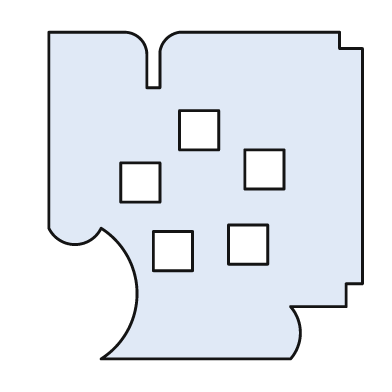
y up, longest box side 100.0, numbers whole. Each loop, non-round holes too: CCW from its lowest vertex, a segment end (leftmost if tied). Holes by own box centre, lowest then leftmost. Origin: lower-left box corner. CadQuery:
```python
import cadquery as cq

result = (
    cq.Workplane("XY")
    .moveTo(16.0, 0.0)
    .lineTo(74.0, 0.0)
    .threePointArc((77.0, 8.0), (74.0, 16.0))
    .lineTo(91.0, 16.0)
    .lineTo(91.0, 23.0)
    .lineTo(96.0, 23.0)
    .lineTo(96.0, 95.0)
    .lineTo(89.0, 95.0)
    .lineTo(89.0, 100.0)
    .lineTo(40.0, 100.0)
    .threePointArc((36.0, 98.0), (34.0, 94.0))
    .lineTo(34.0, 83.0)
    .lineTo(30.0, 83.0)
    .lineTo(30.0, 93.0)
    .threePointArc((28.0, 98.0), (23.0, 100.0))
    .lineTo(0.0, 100.0)
    .lineTo(0.0, 40.0)
    .threePointArc((8.0, 35.0), (16.0, 40.0))
    .threePointArc((27.0, 20.0), (16.0, 0.0))
    .close()
    .moveTo(32.0, 27.0)
    .lineTo(44.0, 27.0)
    .lineTo(44.0, 39.0)
    .lineTo(32.0, 39.0)
    .close()
    .moveTo(55.0, 29.0)
    .lineTo(67.0, 29.0)
    .lineTo(67.0, 41.0)
    .lineTo(55.0, 41.0)
    .close()
    .moveTo(22.0, 48.0)
    .lineTo(34.0, 48.0)
    .lineTo(34.0, 60.0)
    .lineTo(22.0, 60.0)
    .close()
    .moveTo(60.0, 52.0)
    .lineTo(72.0, 52.0)
    .lineTo(72.0, 64.0)
    .lineTo(60.0, 64.0)
    .close()
    .moveTo(40.0, 64.0)
    .lineTo(52.0, 64.0)
    .lineTo(52.0, 76.0)
    .lineTo(40.0, 76.0)
    .close()
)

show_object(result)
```